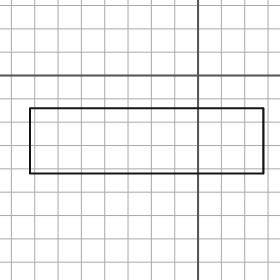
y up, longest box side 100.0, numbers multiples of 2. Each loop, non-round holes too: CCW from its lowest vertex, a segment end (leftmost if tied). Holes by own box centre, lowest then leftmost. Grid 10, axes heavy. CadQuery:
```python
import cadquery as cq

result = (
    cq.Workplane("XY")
    .moveTo(-72.0, -42.0)
    .lineTo(28.0, -42.0)
    .lineTo(28.0, -14.0)
    .lineTo(-72.0, -14.0)
    .close()
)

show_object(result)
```